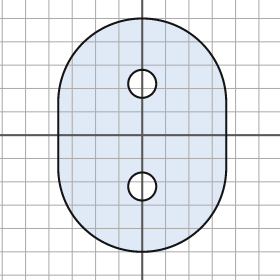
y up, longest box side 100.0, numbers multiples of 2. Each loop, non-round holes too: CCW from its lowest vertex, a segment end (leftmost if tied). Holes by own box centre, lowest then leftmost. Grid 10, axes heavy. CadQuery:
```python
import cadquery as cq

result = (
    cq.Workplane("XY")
    .moveTo(-36.0, -14.0)
    .threePointArc((0.0, -50.0), (36.0, -14.0))
    .lineTo(36.0, 14.0)
    .threePointArc((0.0, 50.0), (-36.0, 14.0))
    .close()
    .moveTo(0.0, -22.0)
    .circle(6.0)
    .moveTo(0.0, 22.0)
    .circle(6.0)
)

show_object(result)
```